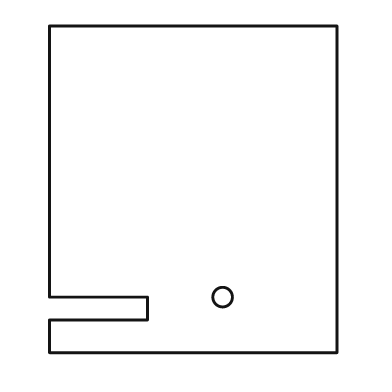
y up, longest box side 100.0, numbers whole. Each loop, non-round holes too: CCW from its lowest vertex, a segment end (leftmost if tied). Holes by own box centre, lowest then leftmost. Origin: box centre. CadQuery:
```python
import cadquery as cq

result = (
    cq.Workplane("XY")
    .moveTo(-44.0, -50.0)
    .lineTo(44.0, -50.0)
    .lineTo(44.0, 50.0)
    .lineTo(-44.0, 50.0)
    .lineTo(-44.0, -33.0)
    .lineTo(-14.0, -33.0)
    .lineTo(-14.0, -40.0)
    .lineTo(-44.0, -40.0)
    .close()
    .moveTo(9.0, -33.0)
    .circle(3.0)
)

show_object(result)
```